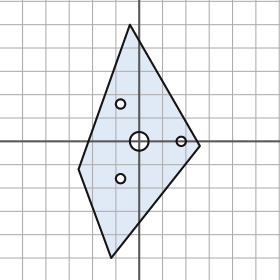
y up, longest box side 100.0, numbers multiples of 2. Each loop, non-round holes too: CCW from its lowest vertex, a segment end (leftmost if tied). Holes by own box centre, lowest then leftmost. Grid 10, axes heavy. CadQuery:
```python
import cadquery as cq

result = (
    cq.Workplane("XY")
    .moveTo(-12.0, -50.0)
    .lineTo(26.0, -2.0)
    .lineTo(-4.0, 50.0)
    .lineTo(-26.0, -12.0)
    .close()
    .moveTo(-8.0, -16.0)
    .circle(2.0)
    .moveTo(0.0, 0.0)
    .circle(4.0)
    .moveTo(18.0, 0.0)
    .circle(2.0)
    .moveTo(-8.0, 16.0)
    .circle(2.0)
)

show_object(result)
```